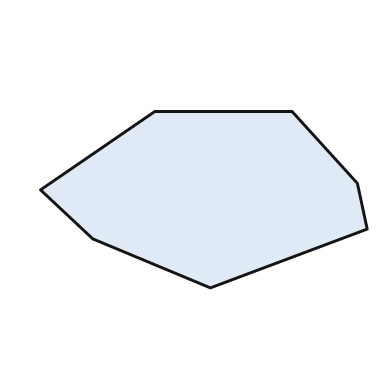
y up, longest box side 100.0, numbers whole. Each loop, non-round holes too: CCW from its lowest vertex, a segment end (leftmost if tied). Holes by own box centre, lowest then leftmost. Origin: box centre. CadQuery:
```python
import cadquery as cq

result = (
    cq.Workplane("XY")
    .moveTo(2.0, -27.0)
    .lineTo(50.0, -9.0)
    .lineTo(47.0, 5.0)
    .lineTo(27.0, 27.0)
    .lineTo(-15.0, 27.0)
    .lineTo(-50.0, 3.0)
    .lineTo(-34.0, -12.0)
    .close()
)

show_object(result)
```